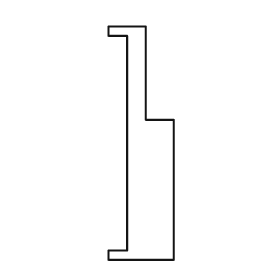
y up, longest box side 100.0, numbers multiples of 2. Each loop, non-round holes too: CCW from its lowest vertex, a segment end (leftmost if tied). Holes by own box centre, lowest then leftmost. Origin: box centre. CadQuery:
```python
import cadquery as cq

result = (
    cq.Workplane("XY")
    .moveTo(-14.0, -50.0)
    .lineTo(14.0, -50.0)
    .lineTo(14.0, 10.0)
    .lineTo(2.0, 10.0)
    .lineTo(2.0, 50.0)
    .lineTo(-14.0, 50.0)
    .lineTo(-14.0, 46.0)
    .lineTo(-6.0, 46.0)
    .lineTo(-6.0, -46.0)
    .lineTo(-14.0, -46.0)
    .close()
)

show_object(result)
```